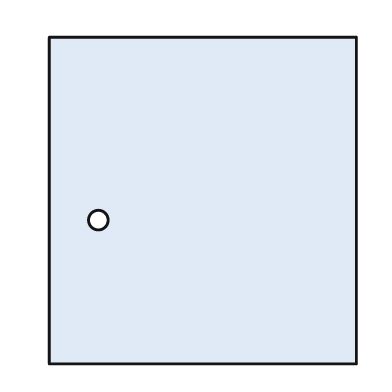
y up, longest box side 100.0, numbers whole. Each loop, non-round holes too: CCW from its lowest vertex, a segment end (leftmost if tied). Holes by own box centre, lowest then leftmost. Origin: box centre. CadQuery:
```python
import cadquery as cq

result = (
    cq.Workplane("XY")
    .moveTo(-47.0, -50.0)
    .lineTo(47.0, -50.0)
    .lineTo(47.0, 50.0)
    .lineTo(-47.0, 50.0)
    .close()
    .moveTo(-32.0, -6.0)
    .circle(3.0)
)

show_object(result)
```